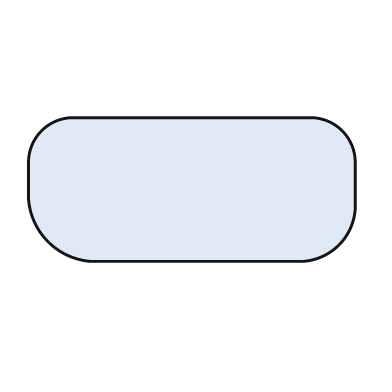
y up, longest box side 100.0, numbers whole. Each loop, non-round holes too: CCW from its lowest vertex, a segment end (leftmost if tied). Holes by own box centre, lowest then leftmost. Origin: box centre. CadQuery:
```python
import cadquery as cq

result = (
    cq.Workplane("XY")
    .moveTo(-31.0, -22.0)
    .lineTo(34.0, -22.0)
    .threePointArc((45.0, -17.0), (50.0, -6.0))
    .lineTo(50.0, 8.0)
    .threePointArc((46.0, 18.0), (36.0, 22.0))
    .lineTo(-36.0, 22.0)
    .threePointArc((-46.0, 18.0), (-50.0, 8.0))
    .lineTo(-50.0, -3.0)
    .threePointArc((-44.0, -16.0), (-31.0, -22.0))
    .close()
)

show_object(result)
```